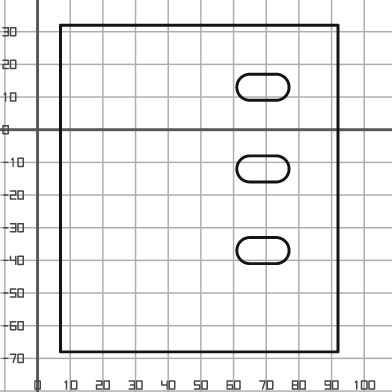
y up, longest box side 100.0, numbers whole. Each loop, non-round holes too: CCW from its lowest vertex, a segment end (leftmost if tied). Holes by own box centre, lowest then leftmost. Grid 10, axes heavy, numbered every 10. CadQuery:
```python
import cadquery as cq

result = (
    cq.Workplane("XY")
    .moveTo(7.0, -68.0)
    .lineTo(92.0, -68.0)
    .lineTo(92.0, 32.0)
    .lineTo(7.0, 32.0)
    .close()
    .moveTo(65.0, -41.0)
    .lineTo(73.0, -41.0)
    .threePointArc((77.0, -37.0), (73.0, -33.0))
    .lineTo(65.0, -33.0)
    .threePointArc((61.0, -37.0), (65.0, -41.0))
    .close()
    .moveTo(65.0, -16.0)
    .lineTo(73.0, -16.0)
    .threePointArc((77.0, -12.0), (73.0, -8.0))
    .lineTo(65.0, -8.0)
    .threePointArc((61.0, -12.0), (65.0, -16.0))
    .close()
    .moveTo(65.0, 9.0)
    .lineTo(73.0, 9.0)
    .threePointArc((77.0, 13.0), (73.0, 17.0))
    .lineTo(65.0, 17.0)
    .threePointArc((61.0, 13.0), (65.0, 9.0))
    .close()
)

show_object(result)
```